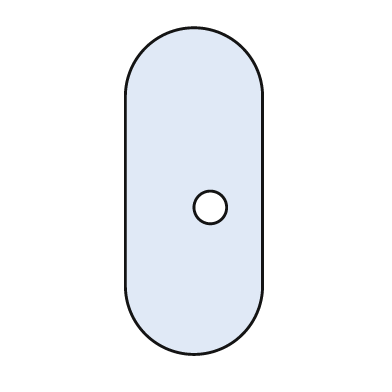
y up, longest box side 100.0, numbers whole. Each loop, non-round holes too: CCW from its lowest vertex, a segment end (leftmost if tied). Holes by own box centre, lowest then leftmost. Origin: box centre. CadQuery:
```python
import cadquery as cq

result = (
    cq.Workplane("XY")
    .moveTo(-21.0, -29.0)
    .threePointArc((0.0, -50.0), (21.0, -29.0))
    .lineTo(21.0, 29.0)
    .threePointArc((0.0, 50.0), (-21.0, 29.0))
    .close()
    .moveTo(5.0, -5.0)
    .circle(5.0)
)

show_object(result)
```